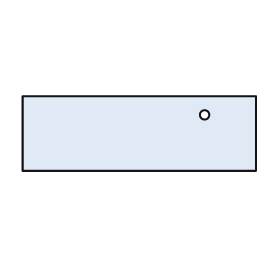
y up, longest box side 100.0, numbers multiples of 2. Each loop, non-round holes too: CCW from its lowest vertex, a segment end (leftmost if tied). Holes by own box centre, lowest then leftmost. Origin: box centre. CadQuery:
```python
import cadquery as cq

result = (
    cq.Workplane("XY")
    .moveTo(-50.0, -16.0)
    .lineTo(50.0, -16.0)
    .lineTo(50.0, 16.0)
    .lineTo(-50.0, 16.0)
    .close()
    .moveTo(28.0, 8.0)
    .circle(2.0)
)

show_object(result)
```